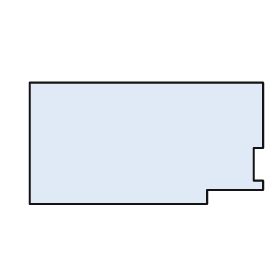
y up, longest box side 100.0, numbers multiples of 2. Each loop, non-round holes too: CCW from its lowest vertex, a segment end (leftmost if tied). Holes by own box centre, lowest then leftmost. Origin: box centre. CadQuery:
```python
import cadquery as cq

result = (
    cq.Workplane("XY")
    .moveTo(-50.0, -26.0)
    .lineTo(26.0, -26.0)
    .lineTo(26.0, -20.0)
    .lineTo(50.0, -20.0)
    .lineTo(50.0, -16.0)
    .lineTo(46.0, -16.0)
    .lineTo(46.0, -2.0)
    .lineTo(50.0, -2.0)
    .lineTo(50.0, 26.0)
    .lineTo(-50.0, 26.0)
    .close()
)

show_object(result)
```